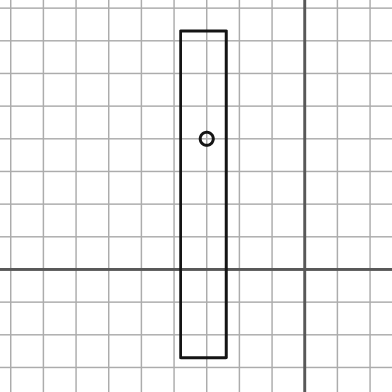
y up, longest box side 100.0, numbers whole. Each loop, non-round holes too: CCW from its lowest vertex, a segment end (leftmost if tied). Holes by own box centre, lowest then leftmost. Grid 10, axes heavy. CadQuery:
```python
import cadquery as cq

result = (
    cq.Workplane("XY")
    .moveTo(-38.0, -27.0)
    .lineTo(-24.0, -27.0)
    .lineTo(-24.0, 73.0)
    .lineTo(-38.0, 73.0)
    .close()
    .moveTo(-30.0, 40.0)
    .circle(2.0)
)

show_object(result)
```